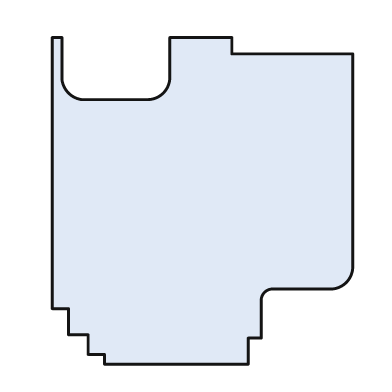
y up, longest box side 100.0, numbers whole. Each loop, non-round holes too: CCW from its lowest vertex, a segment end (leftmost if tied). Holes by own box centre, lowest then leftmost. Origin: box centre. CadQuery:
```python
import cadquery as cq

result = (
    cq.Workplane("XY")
    .moveTo(-30.0, -50.0)
    .lineTo(14.0, -50.0)
    .lineTo(14.0, -42.0)
    .lineTo(18.0, -42.0)
    .lineTo(18.0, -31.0)
    .threePointArc((19.0, -28.0), (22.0, -27.0))
    .lineTo(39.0, -27.0)
    .threePointArc((44.0, -25.0), (46.0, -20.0))
    .lineTo(46.0, 45.0)
    .lineTo(9.0, 45.0)
    .lineTo(9.0, 50.0)
    .lineTo(-10.0, 50.0)
    .lineTo(-10.0, 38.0)
    .threePointArc((-12.0, 33.0), (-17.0, 31.0))
    .lineTo(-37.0, 31.0)
    .threePointArc((-41.0, 33.0), (-43.0, 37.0))
    .lineTo(-43.0, 50.0)
    .lineTo(-46.0, 50.0)
    .lineTo(-46.0, -33.0)
    .lineTo(-41.0, -33.0)
    .lineTo(-41.0, -41.0)
    .lineTo(-35.0, -41.0)
    .lineTo(-35.0, -47.0)
    .lineTo(-30.0, -47.0)
    .close()
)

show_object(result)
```